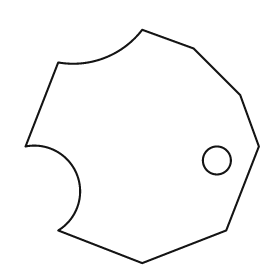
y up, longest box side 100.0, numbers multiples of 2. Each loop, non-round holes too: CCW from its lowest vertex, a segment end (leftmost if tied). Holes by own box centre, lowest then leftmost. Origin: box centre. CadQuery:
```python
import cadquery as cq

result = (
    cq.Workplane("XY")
    .moveTo(0.0, -50.0)
    .lineTo(36.0, -36.0)
    .lineTo(50.0, 0.0)
    .lineTo(42.0, 22.0)
    .lineTo(22.0, 42.0)
    .lineTo(0.0, 50.0)
    .threePointArc((-16.0, 38.0), (-36.0, 36.0))
    .lineTo(-50.0, 0.0)
    .threePointArc((-28.0, -12.0), (-36.0, -36.0))
    .close()
    .moveTo(32.0, -6.0)
    .circle(6.0)
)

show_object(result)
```